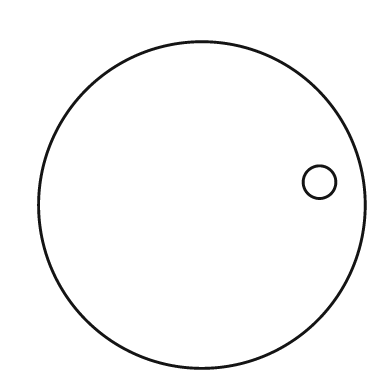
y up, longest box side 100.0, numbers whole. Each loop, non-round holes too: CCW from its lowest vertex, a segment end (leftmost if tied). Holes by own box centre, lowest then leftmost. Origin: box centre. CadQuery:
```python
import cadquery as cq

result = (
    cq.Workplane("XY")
    .moveTo(0.0, 0.0)
    .circle(50.0)
    .moveTo(36.0, 7.0)
    .circle(5.0)
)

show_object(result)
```